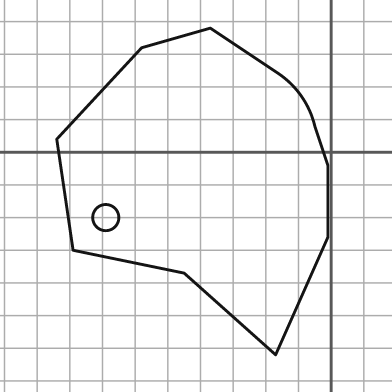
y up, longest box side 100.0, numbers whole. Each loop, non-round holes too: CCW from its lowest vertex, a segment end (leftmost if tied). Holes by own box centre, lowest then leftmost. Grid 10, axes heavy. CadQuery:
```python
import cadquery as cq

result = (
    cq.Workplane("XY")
    .moveTo(-17.0, -62.0)
    .lineTo(-1.0, -26.0)
    .lineTo(-1.0, -4.0)
    .lineTo(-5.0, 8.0)
    .threePointArc((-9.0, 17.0), (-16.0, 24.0))
    .lineTo(-37.0, 38.0)
    .lineTo(-58.0, 32.0)
    .lineTo(-84.0, 4.0)
    .lineTo(-79.0, -30.0)
    .lineTo(-45.0, -37.0)
    .close()
    .moveTo(-69.0, -20.0)
    .circle(4.0)
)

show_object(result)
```